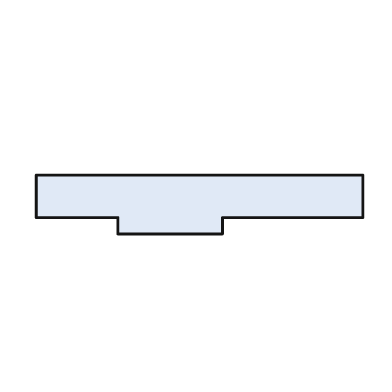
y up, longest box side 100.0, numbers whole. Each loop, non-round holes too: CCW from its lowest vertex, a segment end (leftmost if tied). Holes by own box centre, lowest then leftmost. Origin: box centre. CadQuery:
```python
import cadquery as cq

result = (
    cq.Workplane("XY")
    .moveTo(-25.0, -9.0)
    .lineTo(7.0, -9.0)
    .lineTo(7.0, -4.0)
    .lineTo(50.0, -4.0)
    .lineTo(50.0, 9.0)
    .lineTo(-50.0, 9.0)
    .lineTo(-50.0, -4.0)
    .lineTo(-25.0, -4.0)
    .close()
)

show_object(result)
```